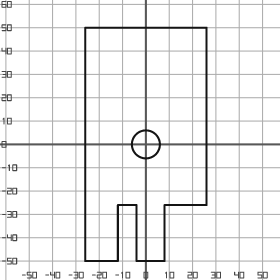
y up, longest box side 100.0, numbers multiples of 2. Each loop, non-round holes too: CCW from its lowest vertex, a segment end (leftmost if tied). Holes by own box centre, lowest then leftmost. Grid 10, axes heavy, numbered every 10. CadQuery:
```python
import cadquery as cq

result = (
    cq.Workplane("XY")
    .moveTo(-26.0, -50.0)
    .lineTo(-12.0, -50.0)
    .lineTo(-12.0, -26.0)
    .lineTo(-4.0, -26.0)
    .lineTo(-4.0, -50.0)
    .lineTo(8.0, -50.0)
    .lineTo(8.0, -26.0)
    .lineTo(26.0, -26.0)
    .lineTo(26.0, 50.0)
    .lineTo(-26.0, 50.0)
    .close()
    .moveTo(0.0, 0.0)
    .circle(6.0)
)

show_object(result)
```